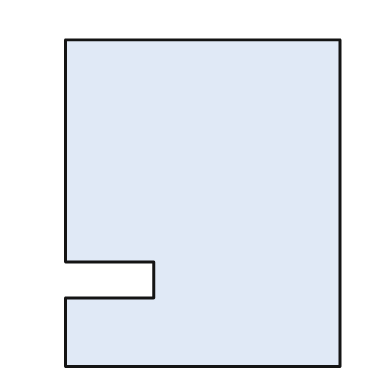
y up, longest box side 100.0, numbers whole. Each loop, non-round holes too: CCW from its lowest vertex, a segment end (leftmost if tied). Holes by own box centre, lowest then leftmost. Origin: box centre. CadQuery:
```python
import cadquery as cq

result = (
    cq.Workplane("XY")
    .moveTo(-42.0, -50.0)
    .lineTo(42.0, -50.0)
    .lineTo(42.0, 50.0)
    .lineTo(-42.0, 50.0)
    .lineTo(-42.0, -18.0)
    .lineTo(-15.0, -18.0)
    .lineTo(-15.0, -29.0)
    .lineTo(-42.0, -29.0)
    .close()
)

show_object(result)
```